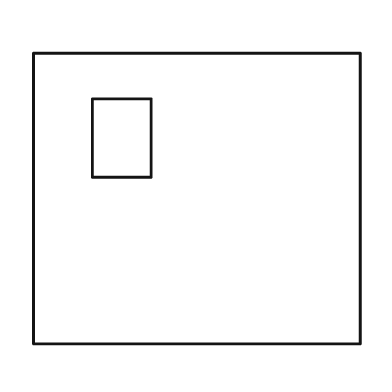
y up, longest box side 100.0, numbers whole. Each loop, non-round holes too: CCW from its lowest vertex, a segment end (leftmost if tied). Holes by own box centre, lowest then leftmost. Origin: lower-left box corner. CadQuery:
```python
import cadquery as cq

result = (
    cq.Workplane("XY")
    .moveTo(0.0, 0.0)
    .lineTo(100.0, 0.0)
    .lineTo(100.0, 89.0)
    .lineTo(0.0, 89.0)
    .close()
    .moveTo(18.0, 51.0)
    .lineTo(36.0, 51.0)
    .lineTo(36.0, 75.0)
    .lineTo(18.0, 75.0)
    .close()
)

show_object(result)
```